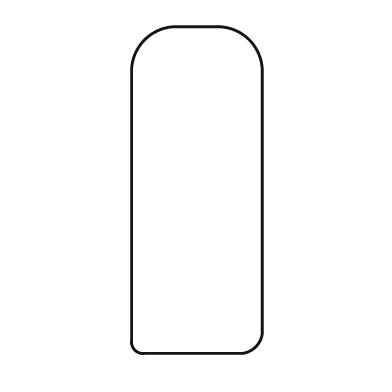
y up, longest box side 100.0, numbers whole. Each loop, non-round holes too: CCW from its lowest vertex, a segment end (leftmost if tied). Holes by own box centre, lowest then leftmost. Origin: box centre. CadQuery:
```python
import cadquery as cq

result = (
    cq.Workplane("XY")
    .moveTo(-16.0, -50.0)
    .lineTo(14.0, -50.0)
    .threePointArc((18.0, -48.0), (20.0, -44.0))
    .lineTo(20.0, 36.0)
    .threePointArc((16.0, 46.0), (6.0, 50.0))
    .lineTo(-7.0, 50.0)
    .threePointArc((-16.0, 46.0), (-20.0, 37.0))
    .lineTo(-20.0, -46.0)
    .threePointArc((-19.0, -49.0), (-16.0, -50.0))
    .close()
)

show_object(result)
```